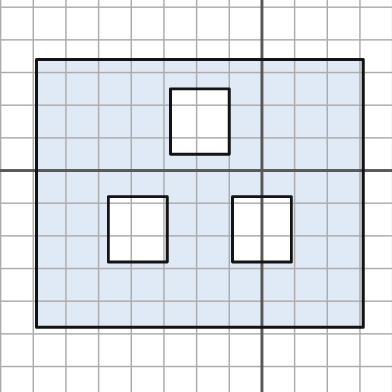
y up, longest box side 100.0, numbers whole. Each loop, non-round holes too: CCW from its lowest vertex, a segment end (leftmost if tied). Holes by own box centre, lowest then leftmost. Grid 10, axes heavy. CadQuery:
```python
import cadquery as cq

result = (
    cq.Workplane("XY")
    .moveTo(-69.0, -48.0)
    .lineTo(31.0, -48.0)
    .lineTo(31.0, 34.0)
    .lineTo(-69.0, 34.0)
    .close()
    .moveTo(-47.0, -28.0)
    .lineTo(-29.0, -28.0)
    .lineTo(-29.0, -8.0)
    .lineTo(-47.0, -8.0)
    .close()
    .moveTo(-9.0, -28.0)
    .lineTo(9.0, -28.0)
    .lineTo(9.0, -8.0)
    .lineTo(-9.0, -8.0)
    .close()
    .moveTo(-28.0, 5.0)
    .lineTo(-10.0, 5.0)
    .lineTo(-10.0, 25.0)
    .lineTo(-28.0, 25.0)
    .close()
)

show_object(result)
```